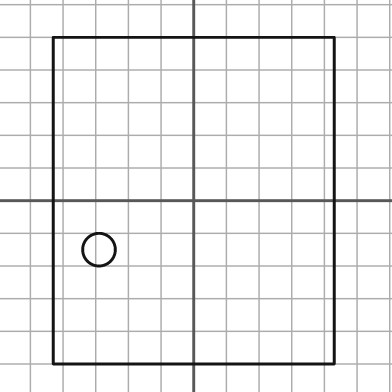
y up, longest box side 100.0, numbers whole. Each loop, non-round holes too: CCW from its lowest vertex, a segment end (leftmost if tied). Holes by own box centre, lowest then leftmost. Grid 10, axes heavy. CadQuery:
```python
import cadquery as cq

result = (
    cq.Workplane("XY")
    .moveTo(-43.0, -50.0)
    .lineTo(43.0, -50.0)
    .lineTo(43.0, 50.0)
    .lineTo(-43.0, 50.0)
    .close()
    .moveTo(-29.0, -15.0)
    .circle(5.0)
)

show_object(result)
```